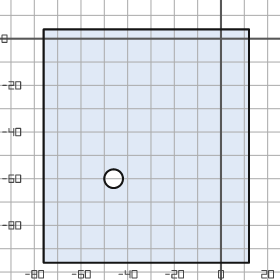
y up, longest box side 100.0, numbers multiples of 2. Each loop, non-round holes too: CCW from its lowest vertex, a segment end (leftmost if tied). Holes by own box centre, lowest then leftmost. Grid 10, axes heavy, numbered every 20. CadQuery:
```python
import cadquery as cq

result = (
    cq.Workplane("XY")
    .moveTo(-76.0, -96.0)
    .lineTo(12.0, -96.0)
    .lineTo(12.0, 4.0)
    .lineTo(-76.0, 4.0)
    .close()
    .moveTo(-46.0, -60.0)
    .circle(4.0)
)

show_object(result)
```